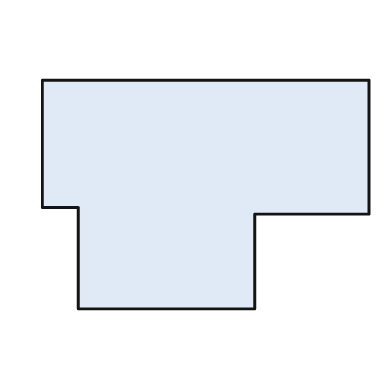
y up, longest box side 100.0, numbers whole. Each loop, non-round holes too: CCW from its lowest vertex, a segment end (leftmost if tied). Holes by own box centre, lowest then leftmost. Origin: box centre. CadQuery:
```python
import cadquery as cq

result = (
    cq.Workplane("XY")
    .moveTo(-39.0, -35.0)
    .lineTo(15.0, -35.0)
    .lineTo(15.0, -6.0)
    .lineTo(50.0, -6.0)
    .lineTo(50.0, 35.0)
    .lineTo(-50.0, 35.0)
    .lineTo(-50.0, -4.0)
    .lineTo(-39.0, -4.0)
    .close()
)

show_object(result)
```